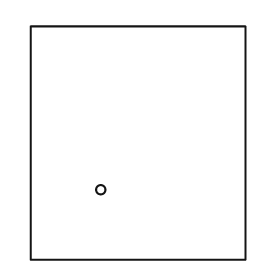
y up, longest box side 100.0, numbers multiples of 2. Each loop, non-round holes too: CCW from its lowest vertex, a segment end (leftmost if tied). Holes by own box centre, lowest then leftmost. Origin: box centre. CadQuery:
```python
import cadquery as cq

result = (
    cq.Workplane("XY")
    .moveTo(-46.0, -50.0)
    .lineTo(46.0, -50.0)
    .lineTo(46.0, 50.0)
    .lineTo(-46.0, 50.0)
    .close()
    .moveTo(-16.0, -20.0)
    .circle(2.0)
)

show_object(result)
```